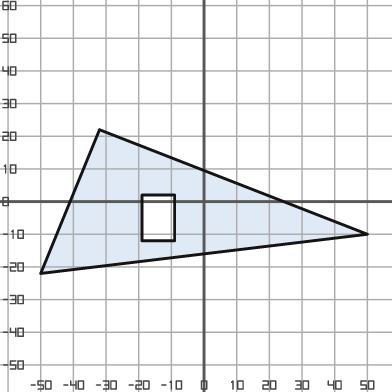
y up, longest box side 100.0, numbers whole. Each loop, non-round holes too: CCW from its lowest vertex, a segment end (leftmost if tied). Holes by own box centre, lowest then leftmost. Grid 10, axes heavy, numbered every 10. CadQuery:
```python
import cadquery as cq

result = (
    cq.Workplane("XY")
    .moveTo(-50.0, -22.0)
    .lineTo(50.0, -10.0)
    .lineTo(-32.0, 22.0)
    .close()
    .moveTo(-19.0, -12.0)
    .lineTo(-9.0, -12.0)
    .lineTo(-9.0, 2.0)
    .lineTo(-19.0, 2.0)
    .close()
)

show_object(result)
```